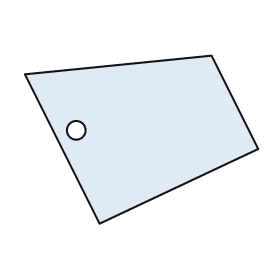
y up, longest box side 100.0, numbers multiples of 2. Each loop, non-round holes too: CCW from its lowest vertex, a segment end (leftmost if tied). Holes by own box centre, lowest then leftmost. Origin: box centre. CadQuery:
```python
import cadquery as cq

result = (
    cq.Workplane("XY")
    .moveTo(-18.0, -36.0)
    .lineTo(50.0, -4.0)
    .lineTo(30.0, 36.0)
    .lineTo(-50.0, 28.0)
    .close()
    .moveTo(-28.0, 4.0)
    .circle(4.0)
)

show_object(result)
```